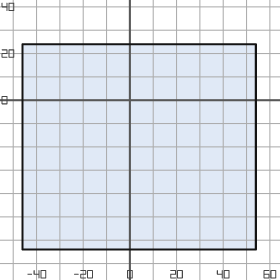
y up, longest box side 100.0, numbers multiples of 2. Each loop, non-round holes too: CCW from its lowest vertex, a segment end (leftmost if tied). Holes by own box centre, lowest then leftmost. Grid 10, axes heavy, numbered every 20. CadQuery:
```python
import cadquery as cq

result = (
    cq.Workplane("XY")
    .moveTo(-46.0, -64.0)
    .lineTo(54.0, -64.0)
    .lineTo(54.0, 24.0)
    .lineTo(-46.0, 24.0)
    .close()
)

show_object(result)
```